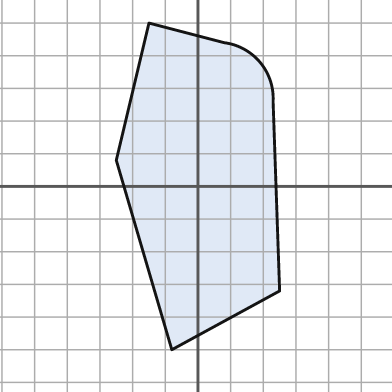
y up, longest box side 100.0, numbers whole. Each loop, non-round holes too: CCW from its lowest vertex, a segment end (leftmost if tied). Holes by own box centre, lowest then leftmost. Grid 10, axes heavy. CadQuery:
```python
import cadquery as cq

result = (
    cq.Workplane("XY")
    .moveTo(-8.0, -50.0)
    .lineTo(25.0, -32.0)
    .lineTo(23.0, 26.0)
    .threePointArc((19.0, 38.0), (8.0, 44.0))
    .lineTo(-15.0, 50.0)
    .lineTo(-25.0, 8.0)
    .close()
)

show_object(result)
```